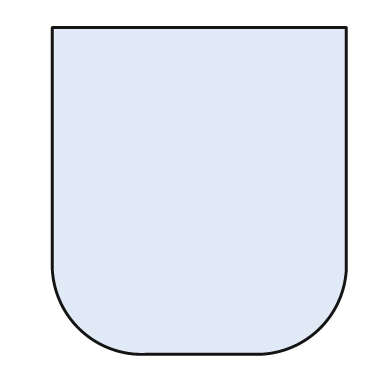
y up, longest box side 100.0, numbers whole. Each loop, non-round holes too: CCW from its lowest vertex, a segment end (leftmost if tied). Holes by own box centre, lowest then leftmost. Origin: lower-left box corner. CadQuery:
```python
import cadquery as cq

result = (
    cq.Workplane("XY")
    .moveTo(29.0, 0.0)
    .lineTo(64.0, 0.0)
    .threePointArc((82.0, 8.0), (90.0, 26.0))
    .lineTo(90.0, 100.0)
    .lineTo(0.0, 100.0)
    .lineTo(0.0, 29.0)
    .threePointArc((8.0, 8.0), (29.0, 0.0))
    .close()
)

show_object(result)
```